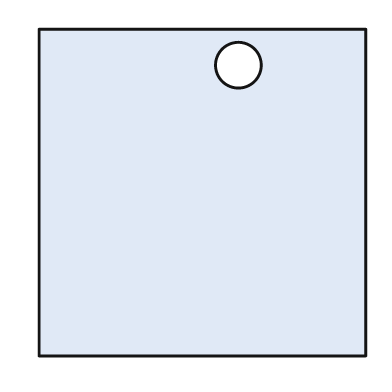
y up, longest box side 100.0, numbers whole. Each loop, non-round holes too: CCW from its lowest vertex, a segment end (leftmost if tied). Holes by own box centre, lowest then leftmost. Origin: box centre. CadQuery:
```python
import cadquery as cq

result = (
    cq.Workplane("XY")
    .moveTo(-50.0, -50.0)
    .lineTo(50.0, -50.0)
    .lineTo(50.0, 50.0)
    .lineTo(-50.0, 50.0)
    .close()
    .moveTo(11.0, 39.0)
    .circle(7.0)
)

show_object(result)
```